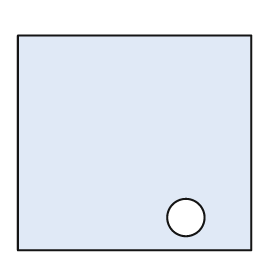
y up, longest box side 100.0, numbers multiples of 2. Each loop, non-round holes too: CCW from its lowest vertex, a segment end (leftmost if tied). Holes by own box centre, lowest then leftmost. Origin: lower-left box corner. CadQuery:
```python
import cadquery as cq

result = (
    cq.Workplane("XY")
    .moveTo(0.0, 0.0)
    .lineTo(100.0, 0.0)
    .lineTo(100.0, 92.0)
    .lineTo(0.0, 92.0)
    .close()
    .moveTo(72.0, 14.0)
    .circle(8.0)
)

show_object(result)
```